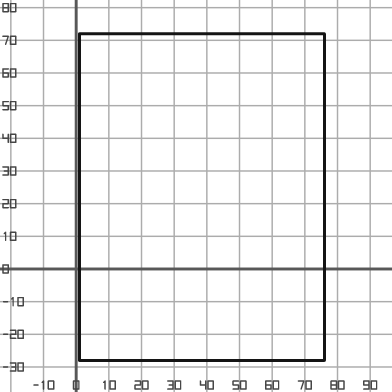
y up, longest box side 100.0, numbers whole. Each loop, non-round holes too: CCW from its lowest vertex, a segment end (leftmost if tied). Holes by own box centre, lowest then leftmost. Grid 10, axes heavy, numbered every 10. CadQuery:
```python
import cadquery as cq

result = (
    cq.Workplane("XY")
    .moveTo(1.0, -28.0)
    .lineTo(76.0, -28.0)
    .lineTo(76.0, 72.0)
    .lineTo(1.0, 72.0)
    .close()
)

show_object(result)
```